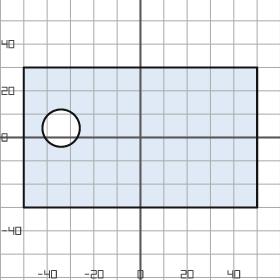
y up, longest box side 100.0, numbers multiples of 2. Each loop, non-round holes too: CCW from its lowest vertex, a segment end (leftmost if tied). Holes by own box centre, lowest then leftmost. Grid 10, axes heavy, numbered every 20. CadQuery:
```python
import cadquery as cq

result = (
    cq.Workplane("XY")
    .moveTo(-50.0, -30.0)
    .lineTo(50.0, -30.0)
    .lineTo(50.0, 30.0)
    .lineTo(-50.0, 30.0)
    .close()
    .moveTo(-34.0, 4.0)
    .circle(8.0)
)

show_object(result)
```